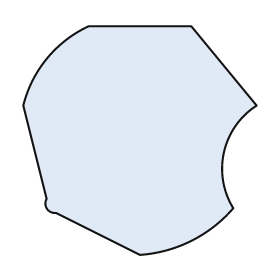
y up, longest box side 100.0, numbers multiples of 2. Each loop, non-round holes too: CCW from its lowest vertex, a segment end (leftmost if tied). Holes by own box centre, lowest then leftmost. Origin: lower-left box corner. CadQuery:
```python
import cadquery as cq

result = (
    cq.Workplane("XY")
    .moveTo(50.0, 0.0)
    .threePointArc((72.0, 6.0), (90.0, 20.0))
    .threePointArc((86.0, 44.0), (100.0, 64.0))
    .lineTo(72.0, 98.0)
    .lineTo(28.0, 98.0)
    .threePointArc((10.0, 84.0), (0.0, 64.0))
    .lineTo(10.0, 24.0)
    .threePointArc((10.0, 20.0), (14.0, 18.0))
    .close()
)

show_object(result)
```